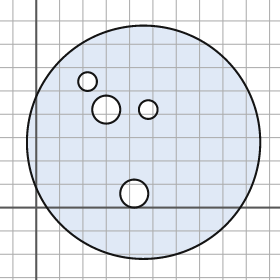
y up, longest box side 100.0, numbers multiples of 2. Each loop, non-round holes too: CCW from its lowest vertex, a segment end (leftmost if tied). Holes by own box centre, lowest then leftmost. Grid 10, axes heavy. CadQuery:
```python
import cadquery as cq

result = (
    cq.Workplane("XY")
    .moveTo(46.0, 28.0)
    .circle(50.0)
    .moveTo(42.0, 6.0)
    .circle(6.0)
    .moveTo(30.0, 42.0)
    .circle(6.0)
    .moveTo(48.0, 42.0)
    .circle(4.0)
    .moveTo(22.0, 54.0)
    .circle(4.0)
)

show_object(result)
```